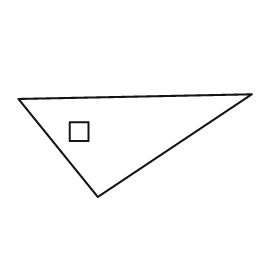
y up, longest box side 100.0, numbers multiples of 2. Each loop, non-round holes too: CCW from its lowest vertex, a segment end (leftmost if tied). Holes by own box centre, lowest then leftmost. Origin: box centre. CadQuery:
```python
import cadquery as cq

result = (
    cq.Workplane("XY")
    .moveTo(-16.0, -22.0)
    .lineTo(50.0, 22.0)
    .lineTo(-50.0, 20.0)
    .close()
    .moveTo(-28.0, 2.0)
    .lineTo(-20.0, 2.0)
    .lineTo(-20.0, 10.0)
    .lineTo(-28.0, 10.0)
    .close()
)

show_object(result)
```